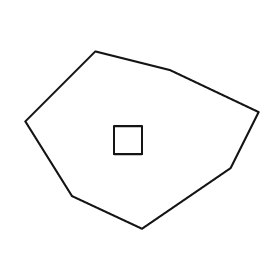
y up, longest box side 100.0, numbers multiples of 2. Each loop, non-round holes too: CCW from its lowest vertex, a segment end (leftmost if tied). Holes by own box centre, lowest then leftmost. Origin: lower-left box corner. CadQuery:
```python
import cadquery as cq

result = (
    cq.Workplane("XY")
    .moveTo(50.0, 0.0)
    .lineTo(88.0, 26.0)
    .lineTo(100.0, 50.0)
    .lineTo(62.0, 68.0)
    .lineTo(30.0, 76.0)
    .lineTo(0.0, 46.0)
    .lineTo(20.0, 14.0)
    .close()
    .moveTo(38.0, 32.0)
    .lineTo(50.0, 32.0)
    .lineTo(50.0, 44.0)
    .lineTo(38.0, 44.0)
    .close()
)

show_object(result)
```